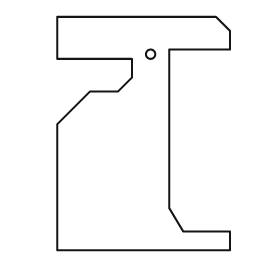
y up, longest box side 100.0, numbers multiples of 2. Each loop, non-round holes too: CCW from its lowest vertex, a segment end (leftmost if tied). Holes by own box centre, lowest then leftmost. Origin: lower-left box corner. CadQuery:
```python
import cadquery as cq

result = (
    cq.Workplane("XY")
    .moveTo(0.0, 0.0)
    .lineTo(74.0, 0.0)
    .lineTo(74.0, 8.0)
    .lineTo(54.0, 8.0)
    .lineTo(48.0, 18.0)
    .lineTo(48.0, 86.0)
    .lineTo(74.0, 86.0)
    .lineTo(74.0, 94.0)
    .lineTo(68.0, 100.0)
    .lineTo(0.0, 100.0)
    .lineTo(0.0, 82.0)
    .lineTo(32.0, 82.0)
    .lineTo(32.0, 74.0)
    .lineTo(26.0, 68.0)
    .lineTo(14.0, 68.0)
    .lineTo(0.0, 54.0)
    .close()
    .moveTo(40.0, 84.0)
    .circle(2.0)
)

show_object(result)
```